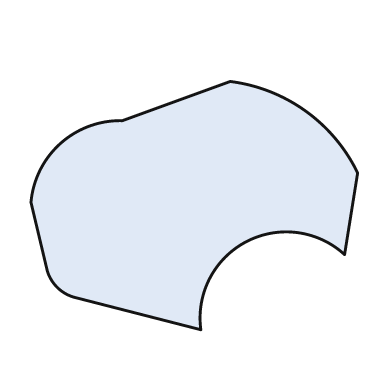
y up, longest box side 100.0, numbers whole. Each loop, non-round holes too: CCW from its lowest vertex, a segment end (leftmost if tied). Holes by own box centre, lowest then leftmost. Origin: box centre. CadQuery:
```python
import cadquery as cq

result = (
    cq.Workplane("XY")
    .moveTo(2.0, -38.0)
    .threePointArc((16.0, -11.0), (46.0, -15.0))
    .lineTo(50.0, 10.0)
    .threePointArc((34.0, 29.0), (11.0, 38.0))
    .lineTo(-22.0, 26.0)
    .threePointArc((-41.0, 19.0), (-50.0, 1.0))
    .lineTo(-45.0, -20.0)
    .threePointArc((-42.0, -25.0), (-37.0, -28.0))
    .close()
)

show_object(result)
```